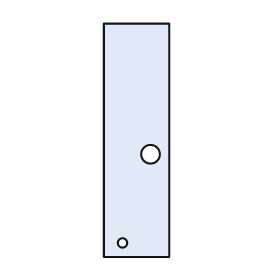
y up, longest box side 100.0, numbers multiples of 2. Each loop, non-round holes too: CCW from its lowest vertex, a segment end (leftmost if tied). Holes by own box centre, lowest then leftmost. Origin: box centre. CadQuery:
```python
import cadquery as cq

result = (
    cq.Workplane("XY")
    .moveTo(-14.0, -50.0)
    .lineTo(14.0, -50.0)
    .lineTo(14.0, 50.0)
    .lineTo(-14.0, 50.0)
    .close()
    .moveTo(-6.0, -44.0)
    .circle(2.0)
    .moveTo(6.0, -6.0)
    .circle(4.0)
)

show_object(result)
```